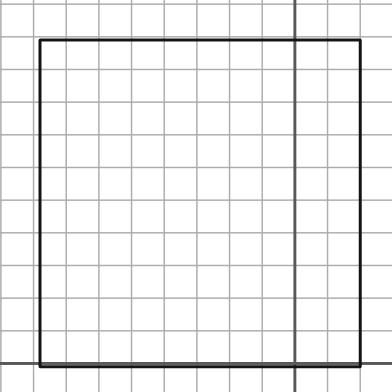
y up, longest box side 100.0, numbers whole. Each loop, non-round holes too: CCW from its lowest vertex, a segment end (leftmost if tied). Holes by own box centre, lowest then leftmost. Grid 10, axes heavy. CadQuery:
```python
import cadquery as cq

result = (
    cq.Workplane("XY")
    .moveTo(-78.0, -1.0)
    .lineTo(20.0, -1.0)
    .lineTo(20.0, 99.0)
    .lineTo(-78.0, 99.0)
    .close()
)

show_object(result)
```